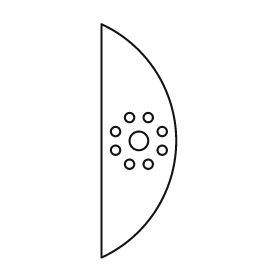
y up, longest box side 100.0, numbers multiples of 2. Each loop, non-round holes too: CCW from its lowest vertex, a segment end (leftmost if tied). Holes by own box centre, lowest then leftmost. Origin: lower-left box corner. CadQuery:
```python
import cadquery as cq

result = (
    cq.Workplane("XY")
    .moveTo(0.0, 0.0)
    .threePointArc((32.0, 50.0), (0.0, 100.0))
    .close()
    .moveTo(12.0, 40.0)
    .circle(2.0)
    .moveTo(20.0, 40.0)
    .circle(2.0)
    .moveTo(6.0, 46.0)
    .circle(2.0)
    .moveTo(26.0, 46.0)
    .circle(2.0)
    .moveTo(16.0, 50.0)
    .circle(4.0)
    .moveTo(6.0, 54.0)
    .circle(2.0)
    .moveTo(26.0, 54.0)
    .circle(2.0)
    .moveTo(12.0, 60.0)
    .circle(2.0)
    .moveTo(20.0, 60.0)
    .circle(2.0)
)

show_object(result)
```